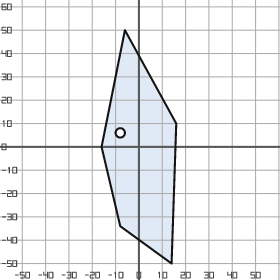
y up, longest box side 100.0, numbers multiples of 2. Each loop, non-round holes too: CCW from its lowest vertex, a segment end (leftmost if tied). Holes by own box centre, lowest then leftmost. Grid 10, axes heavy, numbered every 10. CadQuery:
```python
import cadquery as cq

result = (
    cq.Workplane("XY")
    .moveTo(14.0, -50.0)
    .lineTo(16.0, 10.0)
    .lineTo(-6.0, 50.0)
    .lineTo(-16.0, 0.0)
    .lineTo(-8.0, -34.0)
    .close()
    .moveTo(-8.0, 6.0)
    .circle(2.0)
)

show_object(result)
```